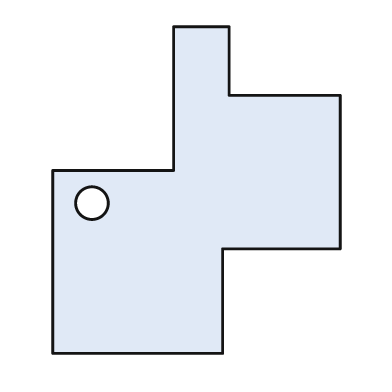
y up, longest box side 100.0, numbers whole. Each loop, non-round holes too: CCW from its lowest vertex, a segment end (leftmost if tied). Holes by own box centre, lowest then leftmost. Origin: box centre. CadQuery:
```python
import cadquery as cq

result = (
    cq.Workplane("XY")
    .moveTo(-44.0, -50.0)
    .lineTo(8.0, -50.0)
    .lineTo(8.0, -18.0)
    .lineTo(44.0, -18.0)
    .lineTo(44.0, 29.0)
    .lineTo(10.0, 29.0)
    .lineTo(10.0, 50.0)
    .lineTo(-7.0, 50.0)
    .lineTo(-7.0, 6.0)
    .lineTo(-44.0, 6.0)
    .close()
    .moveTo(-32.0, -4.0)
    .circle(5.0)
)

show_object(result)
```